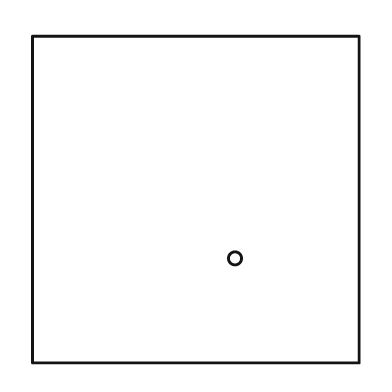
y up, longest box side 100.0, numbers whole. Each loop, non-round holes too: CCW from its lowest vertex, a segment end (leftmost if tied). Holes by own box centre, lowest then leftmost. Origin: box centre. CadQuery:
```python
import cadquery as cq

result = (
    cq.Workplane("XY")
    .moveTo(-50.0, -50.0)
    .lineTo(50.0, -50.0)
    .lineTo(50.0, 50.0)
    .lineTo(-50.0, 50.0)
    .close()
    .moveTo(12.0, -18.0)
    .circle(2.0)
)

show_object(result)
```